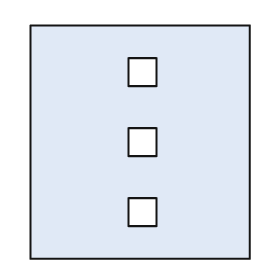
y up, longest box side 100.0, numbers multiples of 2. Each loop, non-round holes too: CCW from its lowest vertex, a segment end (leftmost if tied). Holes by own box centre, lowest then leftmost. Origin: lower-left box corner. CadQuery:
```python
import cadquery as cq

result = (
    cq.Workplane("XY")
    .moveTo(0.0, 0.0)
    .lineTo(94.0, 0.0)
    .lineTo(94.0, 100.0)
    .lineTo(0.0, 100.0)
    .close()
    .moveTo(42.0, 14.0)
    .lineTo(54.0, 14.0)
    .lineTo(54.0, 26.0)
    .lineTo(42.0, 26.0)
    .close()
    .moveTo(42.0, 44.0)
    .lineTo(54.0, 44.0)
    .lineTo(54.0, 56.0)
    .lineTo(42.0, 56.0)
    .close()
    .moveTo(42.0, 74.0)
    .lineTo(54.0, 74.0)
    .lineTo(54.0, 86.0)
    .lineTo(42.0, 86.0)
    .close()
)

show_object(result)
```